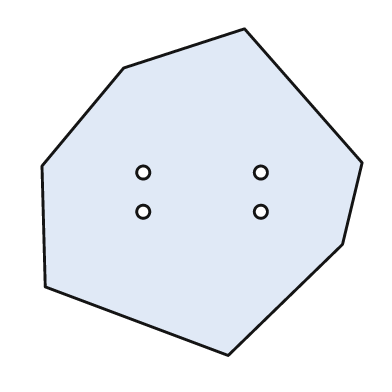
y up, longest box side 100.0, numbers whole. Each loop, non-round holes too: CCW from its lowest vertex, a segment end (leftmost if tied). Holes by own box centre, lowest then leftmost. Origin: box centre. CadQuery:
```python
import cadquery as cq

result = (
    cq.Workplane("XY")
    .moveTo(8.0, -50.0)
    .lineTo(43.0, -16.0)
    .lineTo(49.0, 9.0)
    .lineTo(13.0, 50.0)
    .lineTo(-24.0, 38.0)
    .lineTo(-49.0, 8.0)
    .lineTo(-48.0, -29.0)
    .close()
    .moveTo(-18.0, -6.0)
    .circle(2.0)
    .moveTo(18.0, -6.0)
    .circle(2.0)
    .moveTo(-18.0, 6.0)
    .circle(2.0)
    .moveTo(18.0, 6.0)
    .circle(2.0)
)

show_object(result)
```